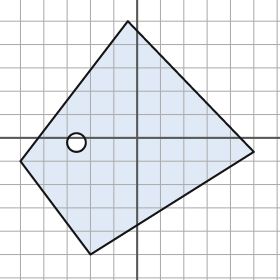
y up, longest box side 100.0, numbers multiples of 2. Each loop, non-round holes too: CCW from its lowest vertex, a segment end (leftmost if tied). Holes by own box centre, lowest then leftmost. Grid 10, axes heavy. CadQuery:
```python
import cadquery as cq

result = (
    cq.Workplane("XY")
    .moveTo(-20.0, -50.0)
    .lineTo(50.0, -6.0)
    .lineTo(-4.0, 50.0)
    .lineTo(-50.0, -10.0)
    .close()
    .moveTo(-26.0, -2.0)
    .circle(4.0)
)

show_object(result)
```